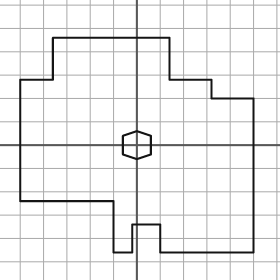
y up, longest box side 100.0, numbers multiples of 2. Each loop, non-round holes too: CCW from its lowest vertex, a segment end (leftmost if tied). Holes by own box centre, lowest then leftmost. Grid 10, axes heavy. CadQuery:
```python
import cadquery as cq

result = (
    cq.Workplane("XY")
    .moveTo(-10.0, -46.0)
    .lineTo(-2.0, -46.0)
    .lineTo(-2.0, -34.0)
    .lineTo(10.0, -34.0)
    .lineTo(10.0, -46.0)
    .lineTo(50.0, -46.0)
    .lineTo(50.0, 20.0)
    .lineTo(32.0, 20.0)
    .lineTo(32.0, 28.0)
    .lineTo(14.0, 28.0)
    .lineTo(14.0, 46.0)
    .lineTo(-36.0, 46.0)
    .lineTo(-36.0, 28.0)
    .lineTo(-50.0, 28.0)
    .lineTo(-50.0, -24.0)
    .lineTo(-10.0, -24.0)
    .close()
    .moveTo(0.0, -6.0)
    .lineTo(6.0, -4.0)
    .lineTo(6.0, 4.0)
    .lineTo(0.0, 6.0)
    .lineTo(-6.0, 4.0)
    .lineTo(-6.0, -4.0)
    .close()
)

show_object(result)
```